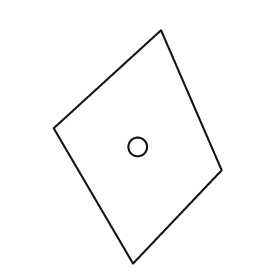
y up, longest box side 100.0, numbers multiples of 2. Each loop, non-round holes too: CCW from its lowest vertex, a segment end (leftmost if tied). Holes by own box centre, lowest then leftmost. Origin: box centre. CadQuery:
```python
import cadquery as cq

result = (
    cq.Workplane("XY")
    .moveTo(-2.0, -50.0)
    .lineTo(36.0, -10.0)
    .lineTo(10.0, 50.0)
    .lineTo(-36.0, 8.0)
    .close()
    .moveTo(0.0, 0.0)
    .circle(4.0)
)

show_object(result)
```